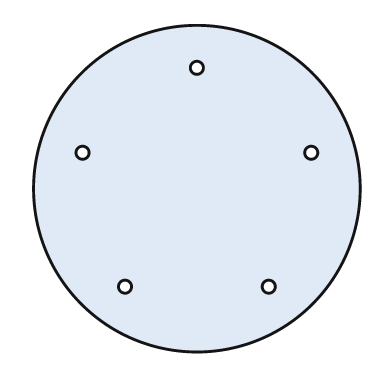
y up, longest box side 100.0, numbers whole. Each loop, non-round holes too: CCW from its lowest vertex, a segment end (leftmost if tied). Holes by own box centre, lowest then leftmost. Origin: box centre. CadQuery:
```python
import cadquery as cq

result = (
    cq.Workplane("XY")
    .moveTo(0.0, 0.0)
    .circle(50.0)
    .moveTo(-22.0, -30.0)
    .circle(2.0)
    .moveTo(22.0, -30.0)
    .circle(2.0)
    .moveTo(-35.0, 11.0)
    .circle(2.0)
    .moveTo(35.0, 11.0)
    .circle(2.0)
    .moveTo(0.0, 37.0)
    .circle(2.0)
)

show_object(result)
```